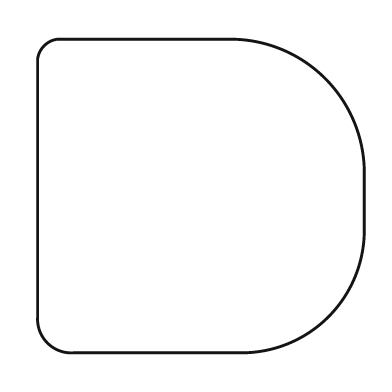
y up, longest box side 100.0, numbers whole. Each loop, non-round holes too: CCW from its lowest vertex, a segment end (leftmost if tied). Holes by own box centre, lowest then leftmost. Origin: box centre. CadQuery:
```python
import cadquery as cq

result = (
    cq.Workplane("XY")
    .moveTo(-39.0, -48.0)
    .lineTo(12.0, -48.0)
    .threePointArc((39.0, -37.0), (50.0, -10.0))
    .lineTo(50.0, 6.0)
    .threePointArc((38.0, 36.0), (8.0, 48.0))
    .lineTo(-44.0, 48.0)
    .threePointArc((-48.0, 46.0), (-50.0, 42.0))
    .lineTo(-50.0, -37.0)
    .threePointArc((-47.0, -45.0), (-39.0, -48.0))
    .close()
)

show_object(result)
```